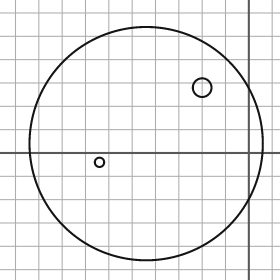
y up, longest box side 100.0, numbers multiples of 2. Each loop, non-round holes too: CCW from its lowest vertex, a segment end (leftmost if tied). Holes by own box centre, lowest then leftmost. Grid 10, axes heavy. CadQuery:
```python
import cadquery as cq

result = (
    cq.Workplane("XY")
    .moveTo(-44.0, 4.0)
    .circle(50.0)
    .moveTo(-64.0, -4.0)
    .circle(2.0)
    .moveTo(-20.0, 28.0)
    .circle(4.0)
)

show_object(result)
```